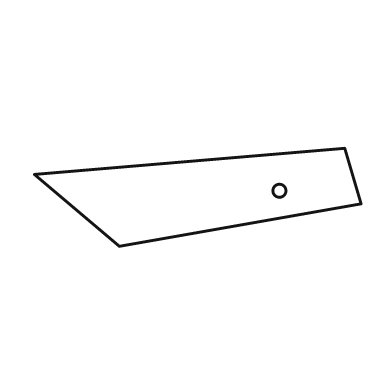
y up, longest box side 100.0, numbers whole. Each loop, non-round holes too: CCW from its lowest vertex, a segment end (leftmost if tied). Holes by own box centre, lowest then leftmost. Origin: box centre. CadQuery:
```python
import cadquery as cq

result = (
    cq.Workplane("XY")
    .moveTo(-24.0, -15.0)
    .lineTo(50.0, -2.0)
    .lineTo(45.0, 15.0)
    .lineTo(-50.0, 7.0)
    .close()
    .moveTo(25.0, 2.0)
    .circle(2.0)
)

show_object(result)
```